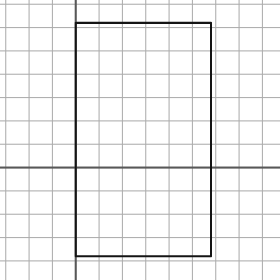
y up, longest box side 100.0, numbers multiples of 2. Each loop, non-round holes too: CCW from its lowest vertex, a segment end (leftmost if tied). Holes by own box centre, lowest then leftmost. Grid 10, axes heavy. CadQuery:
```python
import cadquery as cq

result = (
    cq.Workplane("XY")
    .moveTo(0.0, -38.0)
    .lineTo(58.0, -38.0)
    .lineTo(58.0, 62.0)
    .lineTo(0.0, 62.0)
    .close()
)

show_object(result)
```